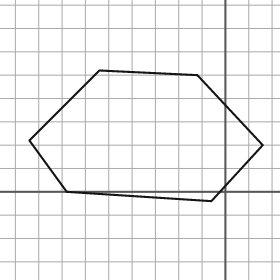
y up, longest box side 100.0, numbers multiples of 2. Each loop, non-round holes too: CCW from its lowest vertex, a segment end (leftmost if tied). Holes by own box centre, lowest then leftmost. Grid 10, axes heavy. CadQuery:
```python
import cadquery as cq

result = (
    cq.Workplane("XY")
    .moveTo(-6.0, -4.0)
    .lineTo(16.0, 20.0)
    .lineTo(-12.0, 50.0)
    .lineTo(-54.0, 52.0)
    .lineTo(-84.0, 22.0)
    .lineTo(-68.0, 0.0)
    .close()
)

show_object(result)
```